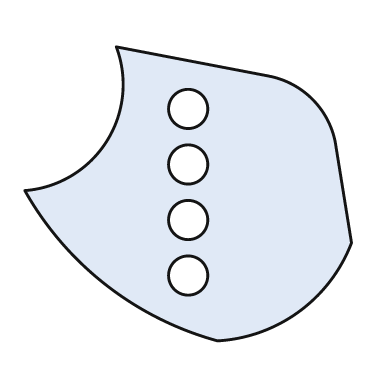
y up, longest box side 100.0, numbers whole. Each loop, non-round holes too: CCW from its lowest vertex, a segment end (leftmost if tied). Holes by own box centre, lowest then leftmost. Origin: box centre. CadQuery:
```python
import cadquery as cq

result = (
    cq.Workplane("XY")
    .moveTo(9.0, -45.0)
    .threePointArc((34.0, -36.0), (50.0, -15.0))
    .lineTo(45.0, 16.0)
    .threePointArc((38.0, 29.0), (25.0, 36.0))
    .lineTo(-22.0, 45.0)
    .threePointArc((-25.0, 16.0), (-50.0, 1.0))
    .threePointArc((-25.0, -28.0), (9.0, -45.0))
    .close()
    .moveTo(0.0, -25.0)
    .circle(6.0)
    .moveTo(0.0, -8.0)
    .circle(6.0)
    .moveTo(0.0, 9.0)
    .circle(6.0)
    .moveTo(0.0, 26.0)
    .circle(6.0)
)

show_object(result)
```